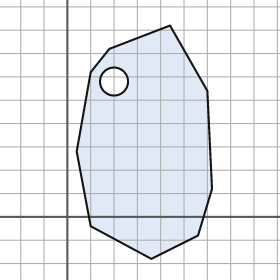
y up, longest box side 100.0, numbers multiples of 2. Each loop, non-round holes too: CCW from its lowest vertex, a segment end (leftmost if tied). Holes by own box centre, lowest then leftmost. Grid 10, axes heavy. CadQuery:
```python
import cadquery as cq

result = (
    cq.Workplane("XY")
    .moveTo(36.0, -18.0)
    .lineTo(56.0, -8.0)
    .lineTo(62.0, 12.0)
    .lineTo(60.0, 54.0)
    .lineTo(44.0, 82.0)
    .lineTo(18.0, 72.0)
    .lineTo(10.0, 62.0)
    .lineTo(4.0, 28.0)
    .lineTo(10.0, -4.0)
    .close()
    .moveTo(20.0, 58.0)
    .circle(6.0)
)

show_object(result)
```